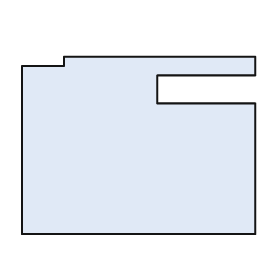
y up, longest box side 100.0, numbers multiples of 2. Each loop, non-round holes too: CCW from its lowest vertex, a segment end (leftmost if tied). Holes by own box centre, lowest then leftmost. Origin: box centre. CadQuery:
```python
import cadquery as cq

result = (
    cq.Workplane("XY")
    .moveTo(-50.0, -38.0)
    .lineTo(50.0, -38.0)
    .lineTo(50.0, 18.0)
    .lineTo(8.0, 18.0)
    .lineTo(8.0, 30.0)
    .lineTo(50.0, 30.0)
    .lineTo(50.0, 38.0)
    .lineTo(-32.0, 38.0)
    .lineTo(-32.0, 34.0)
    .lineTo(-50.0, 34.0)
    .close()
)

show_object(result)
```